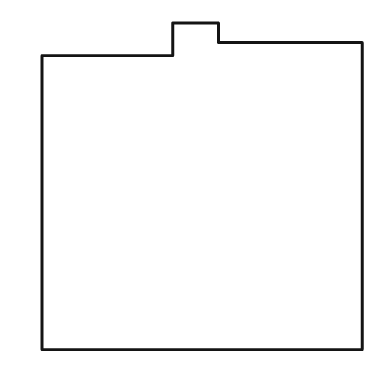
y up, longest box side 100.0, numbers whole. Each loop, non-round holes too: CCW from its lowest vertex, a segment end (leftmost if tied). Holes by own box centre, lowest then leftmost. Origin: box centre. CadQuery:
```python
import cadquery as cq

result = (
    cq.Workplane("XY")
    .moveTo(-49.0, -50.0)
    .lineTo(49.0, -50.0)
    .lineTo(49.0, 44.0)
    .lineTo(5.0, 44.0)
    .lineTo(5.0, 50.0)
    .lineTo(-9.0, 50.0)
    .lineTo(-9.0, 40.0)
    .lineTo(-49.0, 40.0)
    .close()
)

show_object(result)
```